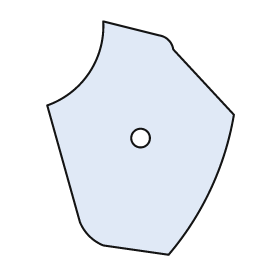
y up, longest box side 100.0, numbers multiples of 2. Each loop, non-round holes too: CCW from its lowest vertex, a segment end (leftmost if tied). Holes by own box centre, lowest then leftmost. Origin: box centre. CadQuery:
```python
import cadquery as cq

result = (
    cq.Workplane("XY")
    .moveTo(12.0, -50.0)
    .threePointArc((30.0, -22.0), (40.0, 10.0))
    .lineTo(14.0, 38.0)
    .threePointArc((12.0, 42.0), (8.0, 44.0))
    .lineTo(-16.0, 50.0)
    .threePointArc((-22.0, 28.0), (-40.0, 14.0))
    .lineTo(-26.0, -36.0)
    .threePointArc((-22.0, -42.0), (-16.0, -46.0))
    .close()
    .moveTo(0.0, 0.0)
    .circle(4.0)
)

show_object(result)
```